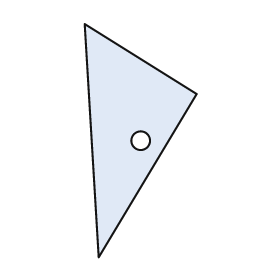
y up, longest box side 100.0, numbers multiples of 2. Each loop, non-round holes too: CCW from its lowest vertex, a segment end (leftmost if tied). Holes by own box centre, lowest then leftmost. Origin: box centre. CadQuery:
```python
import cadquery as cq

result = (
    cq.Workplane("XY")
    .moveTo(-18.0, -50.0)
    .lineTo(24.0, 20.0)
    .lineTo(-24.0, 50.0)
    .close()
    .moveTo(0.0, 0.0)
    .circle(4.0)
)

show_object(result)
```